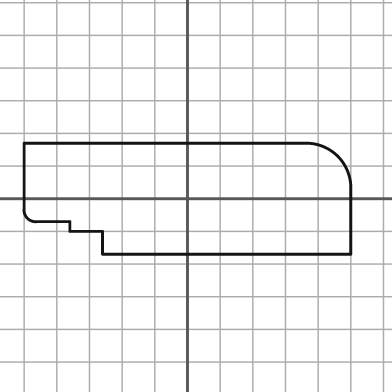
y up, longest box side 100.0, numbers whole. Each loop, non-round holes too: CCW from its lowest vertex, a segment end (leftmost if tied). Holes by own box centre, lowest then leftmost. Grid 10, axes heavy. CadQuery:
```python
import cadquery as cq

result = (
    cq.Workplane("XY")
    .moveTo(-26.0, -17.0)
    .lineTo(50.0, -17.0)
    .lineTo(50.0, 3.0)
    .threePointArc((46.0, 13.0), (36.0, 17.0))
    .lineTo(-50.0, 17.0)
    .lineTo(-50.0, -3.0)
    .threePointArc((-49.0, -6.0), (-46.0, -7.0))
    .lineTo(-36.0, -7.0)
    .lineTo(-36.0, -10.0)
    .lineTo(-26.0, -10.0)
    .close()
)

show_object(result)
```